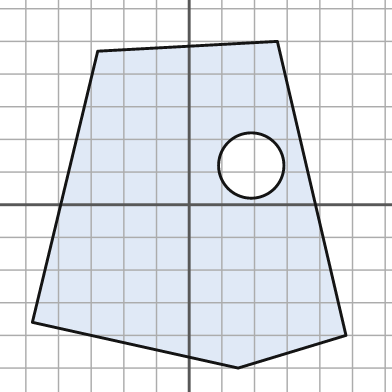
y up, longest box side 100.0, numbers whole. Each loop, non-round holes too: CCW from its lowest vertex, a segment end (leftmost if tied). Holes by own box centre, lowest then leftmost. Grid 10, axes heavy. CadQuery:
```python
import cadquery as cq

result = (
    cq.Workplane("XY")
    .moveTo(15.0, -50.0)
    .lineTo(48.0, -40.0)
    .lineTo(27.0, 50.0)
    .lineTo(-28.0, 47.0)
    .lineTo(-48.0, -36.0)
    .close()
    .moveTo(19.0, 12.0)
    .circle(10.0)
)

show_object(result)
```